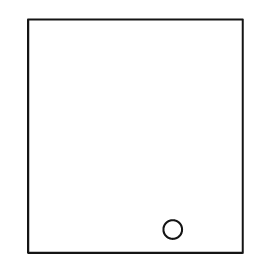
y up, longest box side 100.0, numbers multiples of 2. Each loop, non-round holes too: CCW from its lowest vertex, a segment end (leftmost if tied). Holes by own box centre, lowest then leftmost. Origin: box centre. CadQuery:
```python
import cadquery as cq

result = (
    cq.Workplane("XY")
    .moveTo(-46.0, -50.0)
    .lineTo(46.0, -50.0)
    .lineTo(46.0, 50.0)
    .lineTo(-46.0, 50.0)
    .close()
    .moveTo(16.0, -40.0)
    .circle(4.0)
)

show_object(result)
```